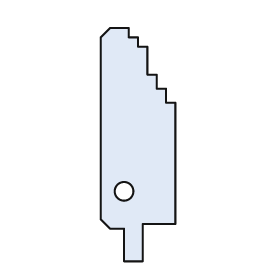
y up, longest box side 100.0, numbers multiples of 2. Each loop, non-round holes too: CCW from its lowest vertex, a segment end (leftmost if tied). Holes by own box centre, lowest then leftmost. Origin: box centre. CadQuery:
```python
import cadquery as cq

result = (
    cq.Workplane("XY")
    .moveTo(-6.0, -50.0)
    .lineTo(2.0, -50.0)
    .lineTo(2.0, -34.0)
    .lineTo(16.0, -34.0)
    .lineTo(16.0, 18.0)
    .lineTo(12.0, 18.0)
    .lineTo(12.0, 24.0)
    .lineTo(8.0, 24.0)
    .lineTo(8.0, 30.0)
    .lineTo(4.0, 30.0)
    .lineTo(4.0, 42.0)
    .lineTo(0.0, 42.0)
    .lineTo(0.0, 46.0)
    .lineTo(-4.0, 46.0)
    .lineTo(-4.0, 50.0)
    .lineTo(-12.0, 50.0)
    .lineTo(-16.0, 46.0)
    .lineTo(-16.0, -32.0)
    .lineTo(-12.0, -36.0)
    .lineTo(-6.0, -36.0)
    .close()
    .moveTo(-6.0, -20.0)
    .circle(4.0)
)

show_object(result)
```